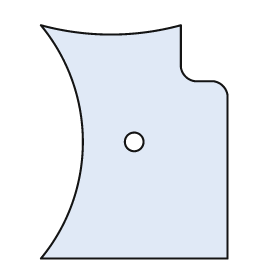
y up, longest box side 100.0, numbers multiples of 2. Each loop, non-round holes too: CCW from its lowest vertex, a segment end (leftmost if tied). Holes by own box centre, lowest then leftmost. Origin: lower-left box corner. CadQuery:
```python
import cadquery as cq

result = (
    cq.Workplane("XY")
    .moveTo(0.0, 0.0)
    .lineTo(80.0, 0.0)
    .lineTo(80.0, 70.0)
    .threePointArc((78.0, 74.0), (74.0, 76.0))
    .lineTo(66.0, 76.0)
    .threePointArc((62.0, 78.0), (60.0, 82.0))
    .lineTo(60.0, 100.0)
    .threePointArc((30.0, 96.0), (0.0, 100.0))
    .threePointArc((18.0, 50.0), (0.0, 0.0))
    .close()
    .moveTo(40.0, 50.0)
    .circle(4.0)
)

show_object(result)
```